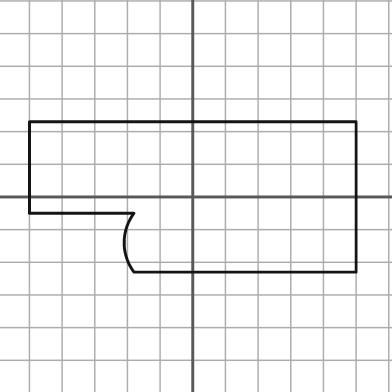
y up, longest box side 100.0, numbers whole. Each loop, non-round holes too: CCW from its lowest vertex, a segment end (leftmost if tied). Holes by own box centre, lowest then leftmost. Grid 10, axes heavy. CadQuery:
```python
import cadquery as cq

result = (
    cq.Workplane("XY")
    .moveTo(-18.0, -23.0)
    .lineTo(50.0, -23.0)
    .lineTo(50.0, 23.0)
    .lineTo(-50.0, 23.0)
    .lineTo(-50.0, -5.0)
    .lineTo(-18.0, -5.0)
    .threePointArc((-21.0, -14.0), (-18.0, -23.0))
    .close()
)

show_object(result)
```